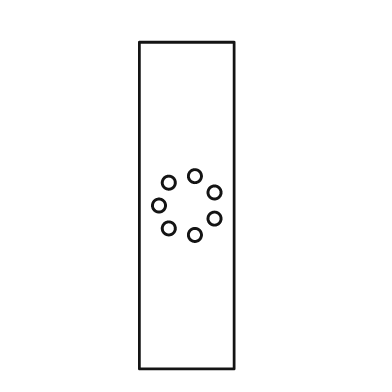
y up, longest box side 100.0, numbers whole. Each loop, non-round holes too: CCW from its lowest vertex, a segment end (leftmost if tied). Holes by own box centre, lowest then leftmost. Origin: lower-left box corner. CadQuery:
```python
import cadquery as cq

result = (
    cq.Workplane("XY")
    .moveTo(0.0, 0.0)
    .lineTo(29.0, 0.0)
    .lineTo(29.0, 100.0)
    .lineTo(0.0, 100.0)
    .close()
    .moveTo(17.0, 41.0)
    .circle(2.0)
    .moveTo(9.0, 43.0)
    .circle(2.0)
    .moveTo(23.0, 46.0)
    .circle(2.0)
    .moveTo(6.0, 50.0)
    .circle(2.0)
    .moveTo(23.0, 54.0)
    .circle(2.0)
    .moveTo(9.0, 57.0)
    .circle(2.0)
    .moveTo(17.0, 59.0)
    .circle(2.0)
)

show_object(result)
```